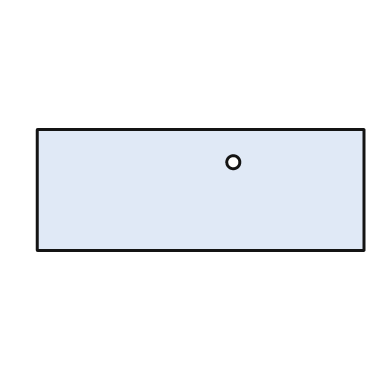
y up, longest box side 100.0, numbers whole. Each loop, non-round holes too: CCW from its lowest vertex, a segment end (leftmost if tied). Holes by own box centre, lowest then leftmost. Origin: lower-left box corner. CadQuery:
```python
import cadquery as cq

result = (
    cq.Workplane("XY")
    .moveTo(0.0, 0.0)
    .lineTo(100.0, 0.0)
    .lineTo(100.0, 37.0)
    .lineTo(0.0, 37.0)
    .close()
    .moveTo(60.0, 27.0)
    .circle(2.0)
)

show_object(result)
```